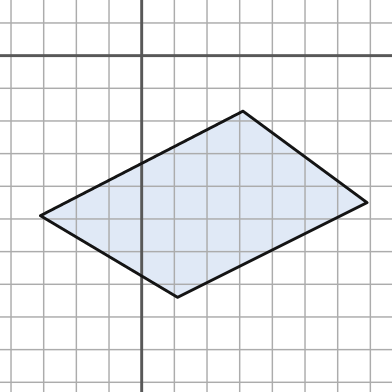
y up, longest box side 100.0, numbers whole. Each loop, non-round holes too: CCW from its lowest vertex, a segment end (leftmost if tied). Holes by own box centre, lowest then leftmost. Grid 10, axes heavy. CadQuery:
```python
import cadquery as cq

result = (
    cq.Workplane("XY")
    .moveTo(11.0, -74.0)
    .lineTo(69.0, -45.0)
    .lineTo(31.0, -17.0)
    .lineTo(-31.0, -49.0)
    .close()
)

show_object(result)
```